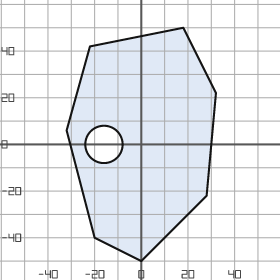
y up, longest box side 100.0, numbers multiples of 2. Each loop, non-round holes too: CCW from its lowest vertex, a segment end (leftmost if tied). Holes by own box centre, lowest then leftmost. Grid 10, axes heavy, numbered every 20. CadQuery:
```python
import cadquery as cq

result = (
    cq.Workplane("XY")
    .moveTo(0.0, -50.0)
    .lineTo(28.0, -22.0)
    .lineTo(32.0, 22.0)
    .lineTo(18.0, 50.0)
    .lineTo(-22.0, 42.0)
    .lineTo(-32.0, 6.0)
    .lineTo(-20.0, -40.0)
    .close()
    .moveTo(-16.0, 0.0)
    .circle(8.0)
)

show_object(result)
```